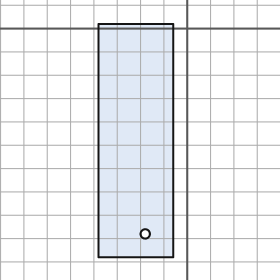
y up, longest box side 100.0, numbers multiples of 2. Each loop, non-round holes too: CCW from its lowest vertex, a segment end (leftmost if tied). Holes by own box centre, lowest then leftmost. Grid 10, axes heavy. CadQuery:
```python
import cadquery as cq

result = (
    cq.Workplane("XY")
    .moveTo(-38.0, -98.0)
    .lineTo(-6.0, -98.0)
    .lineTo(-6.0, 2.0)
    .lineTo(-38.0, 2.0)
    .close()
    .moveTo(-18.0, -88.0)
    .circle(2.0)
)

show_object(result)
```